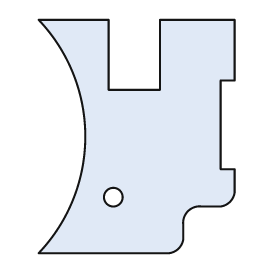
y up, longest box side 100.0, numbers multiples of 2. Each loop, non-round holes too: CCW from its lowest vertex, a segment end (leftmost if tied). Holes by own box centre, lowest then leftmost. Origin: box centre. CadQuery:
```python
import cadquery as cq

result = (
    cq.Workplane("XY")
    .moveTo(-42.0, -50.0)
    .lineTo(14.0, -50.0)
    .threePointArc((18.0, -48.0), (20.0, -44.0))
    .lineTo(20.0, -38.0)
    .threePointArc((22.0, -32.0), (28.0, -30.0))
    .lineTo(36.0, -30.0)
    .threePointArc((40.0, -28.0), (42.0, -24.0))
    .lineTo(42.0, -14.0)
    .lineTo(36.0, -14.0)
    .lineTo(36.0, 24.0)
    .lineTo(42.0, 24.0)
    .lineTo(42.0, 50.0)
    .lineTo(10.0, 50.0)
    .lineTo(10.0, 20.0)
    .lineTo(-12.0, 20.0)
    .lineTo(-12.0, 50.0)
    .lineTo(-42.0, 50.0)
    .threePointArc((-22.0, 0.0), (-42.0, -50.0))
    .close()
    .moveTo(-10.0, -26.0)
    .circle(4.0)
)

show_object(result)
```